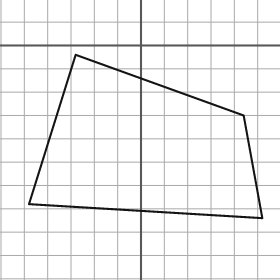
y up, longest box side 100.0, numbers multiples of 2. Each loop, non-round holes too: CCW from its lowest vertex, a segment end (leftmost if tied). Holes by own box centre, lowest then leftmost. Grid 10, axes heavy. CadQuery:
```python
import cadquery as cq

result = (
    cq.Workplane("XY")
    .moveTo(52.0, -74.0)
    .lineTo(44.0, -30.0)
    .lineTo(-28.0, -4.0)
    .lineTo(-48.0, -68.0)
    .close()
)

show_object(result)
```